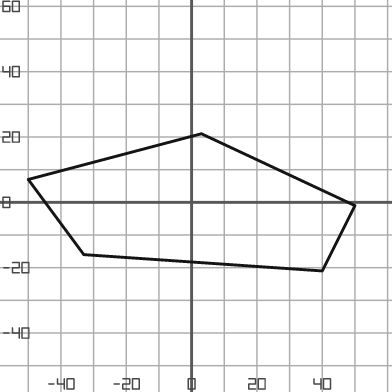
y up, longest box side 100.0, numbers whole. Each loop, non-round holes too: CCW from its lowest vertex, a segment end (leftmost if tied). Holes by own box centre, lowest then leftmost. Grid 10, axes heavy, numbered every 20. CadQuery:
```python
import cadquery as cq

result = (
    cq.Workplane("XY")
    .moveTo(40.0, -21.0)
    .lineTo(50.0, -1.0)
    .lineTo(3.0, 21.0)
    .lineTo(-50.0, 7.0)
    .lineTo(-33.0, -16.0)
    .close()
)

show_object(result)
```